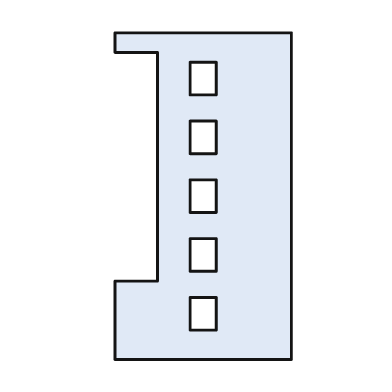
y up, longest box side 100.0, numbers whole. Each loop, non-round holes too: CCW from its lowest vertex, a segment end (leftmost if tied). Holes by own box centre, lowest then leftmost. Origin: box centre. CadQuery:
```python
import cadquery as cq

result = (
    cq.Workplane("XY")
    .moveTo(-27.0, -50.0)
    .lineTo(27.0, -50.0)
    .lineTo(27.0, 50.0)
    .lineTo(-27.0, 50.0)
    .lineTo(-27.0, 44.0)
    .lineTo(-14.0, 44.0)
    .lineTo(-14.0, -26.0)
    .lineTo(-27.0, -26.0)
    .close()
    .moveTo(-4.0, -41.0)
    .lineTo(4.0, -41.0)
    .lineTo(4.0, -31.0)
    .lineTo(-4.0, -31.0)
    .close()
    .moveTo(-4.0, -23.0)
    .lineTo(4.0, -23.0)
    .lineTo(4.0, -13.0)
    .lineTo(-4.0, -13.0)
    .close()
    .moveTo(-4.0, -5.0)
    .lineTo(4.0, -5.0)
    .lineTo(4.0, 5.0)
    .lineTo(-4.0, 5.0)
    .close()
    .moveTo(-4.0, 13.0)
    .lineTo(4.0, 13.0)
    .lineTo(4.0, 23.0)
    .lineTo(-4.0, 23.0)
    .close()
    .moveTo(-4.0, 31.0)
    .lineTo(4.0, 31.0)
    .lineTo(4.0, 41.0)
    .lineTo(-4.0, 41.0)
    .close()
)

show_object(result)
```